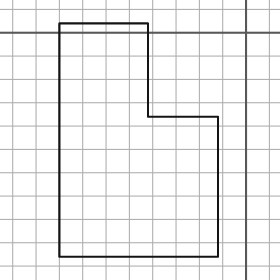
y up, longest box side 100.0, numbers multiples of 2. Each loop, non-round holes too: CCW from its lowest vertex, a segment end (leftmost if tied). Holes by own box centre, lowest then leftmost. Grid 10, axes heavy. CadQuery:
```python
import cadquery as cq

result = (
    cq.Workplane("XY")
    .moveTo(-80.0, -96.0)
    .lineTo(-12.0, -96.0)
    .lineTo(-12.0, -36.0)
    .lineTo(-42.0, -36.0)
    .lineTo(-42.0, 4.0)
    .lineTo(-80.0, 4.0)
    .close()
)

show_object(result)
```